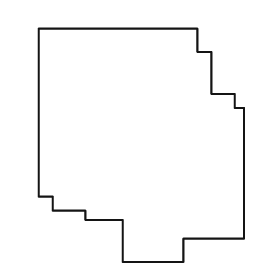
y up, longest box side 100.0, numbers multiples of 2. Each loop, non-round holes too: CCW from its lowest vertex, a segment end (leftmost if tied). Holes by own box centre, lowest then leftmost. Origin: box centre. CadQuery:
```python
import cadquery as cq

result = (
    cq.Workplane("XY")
    .moveTo(-8.0, -50.0)
    .lineTo(18.0, -50.0)
    .lineTo(18.0, -40.0)
    .lineTo(44.0, -40.0)
    .lineTo(44.0, 16.0)
    .lineTo(40.0, 16.0)
    .lineTo(40.0, 22.0)
    .lineTo(30.0, 22.0)
    .lineTo(30.0, 40.0)
    .lineTo(24.0, 40.0)
    .lineTo(24.0, 50.0)
    .lineTo(-44.0, 50.0)
    .lineTo(-44.0, -22.0)
    .lineTo(-38.0, -22.0)
    .lineTo(-38.0, -28.0)
    .lineTo(-24.0, -28.0)
    .lineTo(-24.0, -32.0)
    .lineTo(-8.0, -32.0)
    .close()
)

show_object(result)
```